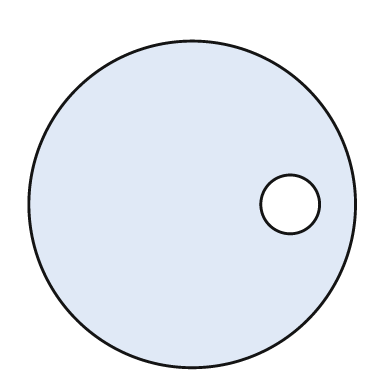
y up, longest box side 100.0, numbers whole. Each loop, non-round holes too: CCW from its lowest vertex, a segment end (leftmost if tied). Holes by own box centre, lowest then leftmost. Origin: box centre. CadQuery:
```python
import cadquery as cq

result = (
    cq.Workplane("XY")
    .moveTo(0.0, 0.0)
    .circle(50.0)
    .moveTo(30.0, 0.0)
    .circle(9.0)
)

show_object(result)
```